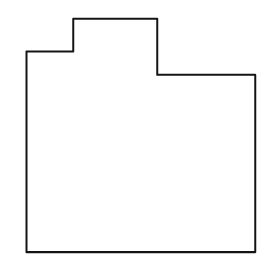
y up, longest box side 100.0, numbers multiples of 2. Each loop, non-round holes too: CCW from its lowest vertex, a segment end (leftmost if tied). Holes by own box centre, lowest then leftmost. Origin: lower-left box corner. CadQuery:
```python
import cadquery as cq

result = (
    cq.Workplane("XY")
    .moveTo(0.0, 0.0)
    .lineTo(98.0, 0.0)
    .lineTo(98.0, 76.0)
    .lineTo(56.0, 76.0)
    .lineTo(56.0, 100.0)
    .lineTo(20.0, 100.0)
    .lineTo(20.0, 86.0)
    .lineTo(0.0, 86.0)
    .close()
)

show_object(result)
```